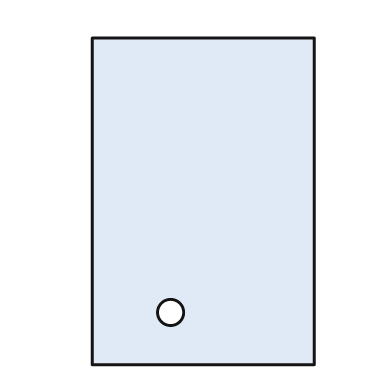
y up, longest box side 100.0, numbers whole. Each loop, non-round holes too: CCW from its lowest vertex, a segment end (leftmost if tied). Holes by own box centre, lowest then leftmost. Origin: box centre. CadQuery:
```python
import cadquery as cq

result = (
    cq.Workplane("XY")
    .moveTo(-34.0, -50.0)
    .lineTo(34.0, -50.0)
    .lineTo(34.0, 50.0)
    .lineTo(-34.0, 50.0)
    .close()
    .moveTo(-10.0, -34.0)
    .circle(4.0)
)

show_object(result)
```